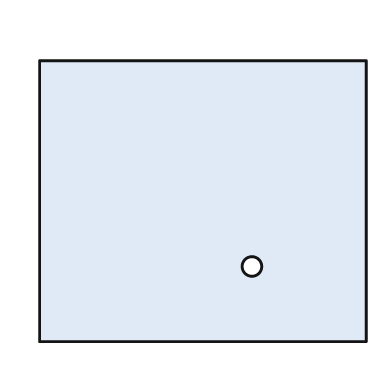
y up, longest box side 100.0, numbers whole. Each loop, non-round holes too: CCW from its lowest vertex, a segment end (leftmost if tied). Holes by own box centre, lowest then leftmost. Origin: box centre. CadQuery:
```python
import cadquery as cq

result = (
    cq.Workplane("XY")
    .moveTo(-50.0, -43.0)
    .lineTo(50.0, -43.0)
    .lineTo(50.0, 43.0)
    .lineTo(-50.0, 43.0)
    .close()
    .moveTo(15.0, -20.0)
    .circle(3.0)
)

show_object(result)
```